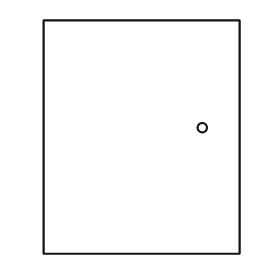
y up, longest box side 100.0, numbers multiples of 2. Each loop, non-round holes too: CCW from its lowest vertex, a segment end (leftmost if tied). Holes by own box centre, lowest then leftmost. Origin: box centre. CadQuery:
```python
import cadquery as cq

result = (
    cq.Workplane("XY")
    .moveTo(-42.0, -50.0)
    .lineTo(42.0, -50.0)
    .lineTo(42.0, 50.0)
    .lineTo(-42.0, 50.0)
    .close()
    .moveTo(26.0, 4.0)
    .circle(2.0)
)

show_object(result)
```